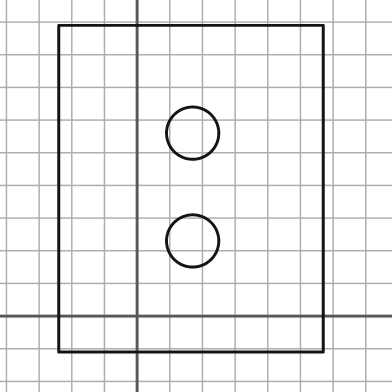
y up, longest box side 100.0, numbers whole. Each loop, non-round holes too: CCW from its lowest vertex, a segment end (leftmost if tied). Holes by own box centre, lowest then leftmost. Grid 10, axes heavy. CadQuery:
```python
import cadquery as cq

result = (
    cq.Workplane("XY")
    .moveTo(-24.0, -11.0)
    .lineTo(57.0, -11.0)
    .lineTo(57.0, 89.0)
    .lineTo(-24.0, 89.0)
    .close()
    .moveTo(17.0, 23.0)
    .circle(8.0)
    .moveTo(17.0, 56.0)
    .circle(8.0)
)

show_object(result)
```